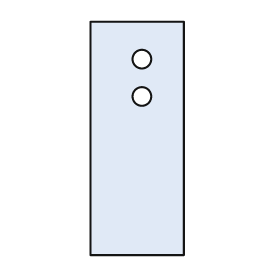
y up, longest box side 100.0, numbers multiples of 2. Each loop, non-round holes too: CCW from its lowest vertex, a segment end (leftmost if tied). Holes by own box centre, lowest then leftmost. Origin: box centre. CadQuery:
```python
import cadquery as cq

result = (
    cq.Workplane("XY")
    .moveTo(-20.0, -50.0)
    .lineTo(20.0, -50.0)
    .lineTo(20.0, 50.0)
    .lineTo(-20.0, 50.0)
    .close()
    .moveTo(2.0, 18.0)
    .circle(4.0)
    .moveTo(2.0, 34.0)
    .circle(4.0)
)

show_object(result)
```